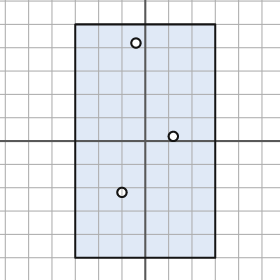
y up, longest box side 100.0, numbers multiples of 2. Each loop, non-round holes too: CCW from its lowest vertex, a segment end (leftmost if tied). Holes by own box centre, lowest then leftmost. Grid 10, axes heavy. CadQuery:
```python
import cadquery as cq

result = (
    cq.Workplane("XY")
    .moveTo(-30.0, -50.0)
    .lineTo(30.0, -50.0)
    .lineTo(30.0, 50.0)
    .lineTo(-30.0, 50.0)
    .close()
    .moveTo(-10.0, -22.0)
    .circle(2.0)
    .moveTo(12.0, 2.0)
    .circle(2.0)
    .moveTo(-4.0, 42.0)
    .circle(2.0)
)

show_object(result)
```